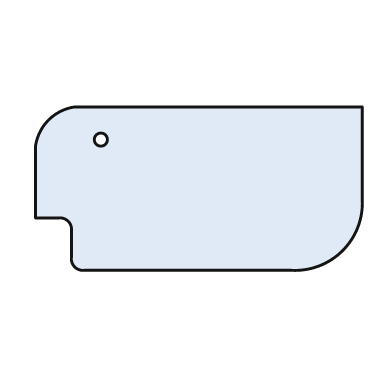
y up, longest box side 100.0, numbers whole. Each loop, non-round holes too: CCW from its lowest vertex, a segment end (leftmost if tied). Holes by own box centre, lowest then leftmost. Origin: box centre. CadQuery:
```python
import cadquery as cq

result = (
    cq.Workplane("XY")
    .moveTo(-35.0, -25.0)
    .lineTo(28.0, -25.0)
    .threePointArc((44.0, -19.0), (50.0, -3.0))
    .lineTo(50.0, 25.0)
    .lineTo(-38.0, 25.0)
    .threePointArc((-46.0, 21.0), (-50.0, 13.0))
    .lineTo(-50.0, -9.0)
    .lineTo(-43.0, -9.0)
    .threePointArc((-40.0, -10.0), (-39.0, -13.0))
    .lineTo(-39.0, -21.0)
    .threePointArc((-38.0, -24.0), (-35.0, -25.0))
    .close()
    .moveTo(-30.0, 15.0)
    .circle(2.0)
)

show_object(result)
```